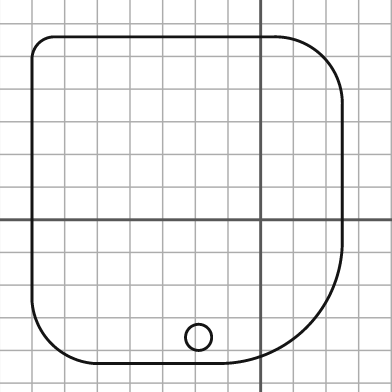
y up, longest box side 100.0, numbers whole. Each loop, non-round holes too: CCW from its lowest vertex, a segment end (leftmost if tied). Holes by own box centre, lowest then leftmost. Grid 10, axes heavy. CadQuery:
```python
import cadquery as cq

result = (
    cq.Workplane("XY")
    .moveTo(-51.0, -44.0)
    .lineTo(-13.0, -44.0)
    .threePointArc((14.0, -33.0), (25.0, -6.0))
    .lineTo(25.0, 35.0)
    .threePointArc((19.0, 50.0), (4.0, 56.0))
    .lineTo(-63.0, 56.0)
    .threePointArc((-68.0, 54.0), (-70.0, 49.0))
    .lineTo(-70.0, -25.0)
    .threePointArc((-64.0, -38.0), (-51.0, -44.0))
    .close()
    .moveTo(-19.0, -36.0)
    .circle(4.0)
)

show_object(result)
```